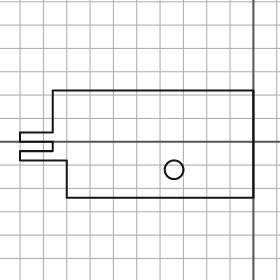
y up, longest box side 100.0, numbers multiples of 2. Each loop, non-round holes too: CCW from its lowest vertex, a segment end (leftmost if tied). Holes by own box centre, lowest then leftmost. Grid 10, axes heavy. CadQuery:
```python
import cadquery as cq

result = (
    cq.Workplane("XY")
    .moveTo(-80.0, -24.0)
    .lineTo(0.0, -24.0)
    .lineTo(0.0, 22.0)
    .lineTo(-86.0, 22.0)
    .lineTo(-86.0, 4.0)
    .lineTo(-100.0, 4.0)
    .lineTo(-100.0, 0.0)
    .lineTo(-86.0, 0.0)
    .lineTo(-86.0, -4.0)
    .lineTo(-100.0, -4.0)
    .lineTo(-100.0, -8.0)
    .lineTo(-80.0, -8.0)
    .close()
    .moveTo(-34.0, -12.0)
    .circle(4.0)
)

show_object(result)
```